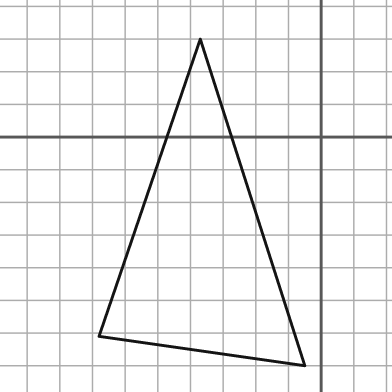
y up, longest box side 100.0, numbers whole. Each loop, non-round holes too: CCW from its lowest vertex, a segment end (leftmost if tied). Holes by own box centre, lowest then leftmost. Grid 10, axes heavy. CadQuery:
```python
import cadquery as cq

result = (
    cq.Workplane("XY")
    .moveTo(-5.0, -70.0)
    .lineTo(-37.0, 30.0)
    .lineTo(-68.0, -61.0)
    .close()
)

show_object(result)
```